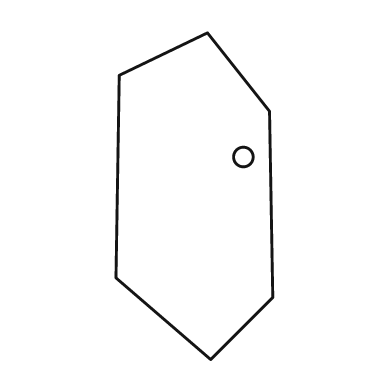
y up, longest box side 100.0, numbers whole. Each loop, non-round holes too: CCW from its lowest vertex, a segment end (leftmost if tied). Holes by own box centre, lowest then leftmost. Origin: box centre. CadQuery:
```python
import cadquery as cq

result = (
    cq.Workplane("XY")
    .moveTo(5.0, -50.0)
    .lineTo(24.0, -31.0)
    .lineTo(23.0, 26.0)
    .lineTo(4.0, 50.0)
    .lineTo(-23.0, 37.0)
    .lineTo(-24.0, -25.0)
    .close()
    .moveTo(15.0, 12.0)
    .circle(3.0)
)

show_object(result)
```